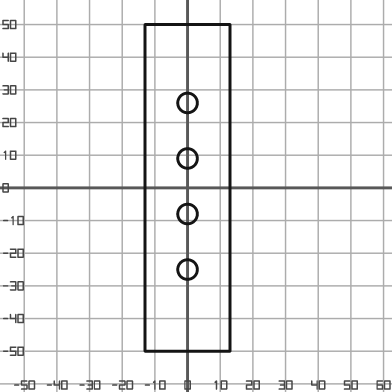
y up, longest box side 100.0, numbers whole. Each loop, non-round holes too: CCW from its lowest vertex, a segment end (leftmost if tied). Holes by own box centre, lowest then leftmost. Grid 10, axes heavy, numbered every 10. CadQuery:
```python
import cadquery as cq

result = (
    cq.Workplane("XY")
    .moveTo(-13.0, -50.0)
    .lineTo(13.0, -50.0)
    .lineTo(13.0, 50.0)
    .lineTo(-13.0, 50.0)
    .close()
    .moveTo(0.0, -25.0)
    .circle(3.0)
    .moveTo(0.0, -8.0)
    .circle(3.0)
    .moveTo(0.0, 9.0)
    .circle(3.0)
    .moveTo(0.0, 26.0)
    .circle(3.0)
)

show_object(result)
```